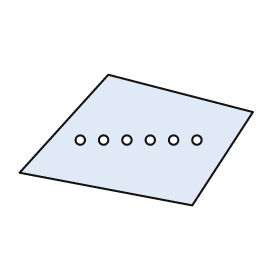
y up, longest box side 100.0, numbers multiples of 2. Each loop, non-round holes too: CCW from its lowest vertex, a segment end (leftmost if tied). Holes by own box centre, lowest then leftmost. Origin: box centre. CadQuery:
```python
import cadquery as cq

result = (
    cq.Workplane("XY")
    .moveTo(24.0, -28.0)
    .lineTo(50.0, 12.0)
    .lineTo(-12.0, 28.0)
    .lineTo(-50.0, -14.0)
    .close()
    .moveTo(-24.0, 0.0)
    .circle(2.0)
    .moveTo(-14.0, 0.0)
    .circle(2.0)
    .moveTo(-4.0, 0.0)
    .circle(2.0)
    .moveTo(6.0, 0.0)
    .circle(2.0)
    .moveTo(16.0, 0.0)
    .circle(2.0)
    .moveTo(26.0, 0.0)
    .circle(2.0)
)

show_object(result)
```